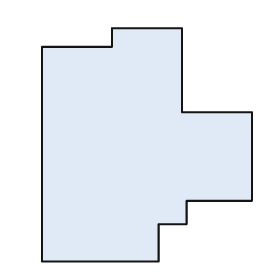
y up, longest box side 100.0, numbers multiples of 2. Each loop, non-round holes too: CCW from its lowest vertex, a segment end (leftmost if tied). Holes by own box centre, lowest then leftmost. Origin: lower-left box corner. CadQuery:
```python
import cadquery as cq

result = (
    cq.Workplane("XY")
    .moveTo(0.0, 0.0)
    .lineTo(50.0, 0.0)
    .lineTo(50.0, 16.0)
    .lineTo(62.0, 16.0)
    .lineTo(62.0, 26.0)
    .lineTo(90.0, 26.0)
    .lineTo(90.0, 64.0)
    .lineTo(60.0, 64.0)
    .lineTo(60.0, 100.0)
    .lineTo(30.0, 100.0)
    .lineTo(30.0, 92.0)
    .lineTo(0.0, 92.0)
    .close()
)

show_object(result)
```